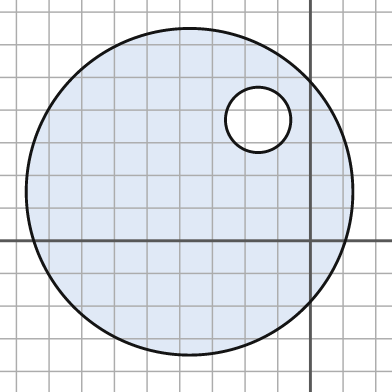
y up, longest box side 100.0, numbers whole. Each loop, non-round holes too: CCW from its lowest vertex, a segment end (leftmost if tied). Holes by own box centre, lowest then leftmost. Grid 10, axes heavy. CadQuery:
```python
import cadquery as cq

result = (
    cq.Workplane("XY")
    .moveTo(-37.0, 15.0)
    .circle(50.0)
    .moveTo(-16.0, 37.0)
    .circle(10.0)
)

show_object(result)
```